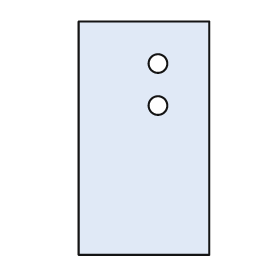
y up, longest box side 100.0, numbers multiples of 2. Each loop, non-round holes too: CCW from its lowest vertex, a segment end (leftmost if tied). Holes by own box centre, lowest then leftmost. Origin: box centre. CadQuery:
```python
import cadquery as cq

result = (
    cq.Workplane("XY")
    .moveTo(-28.0, -50.0)
    .lineTo(28.0, -50.0)
    .lineTo(28.0, 50.0)
    .lineTo(-28.0, 50.0)
    .close()
    .moveTo(6.0, 14.0)
    .circle(4.0)
    .moveTo(6.0, 32.0)
    .circle(4.0)
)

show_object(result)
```